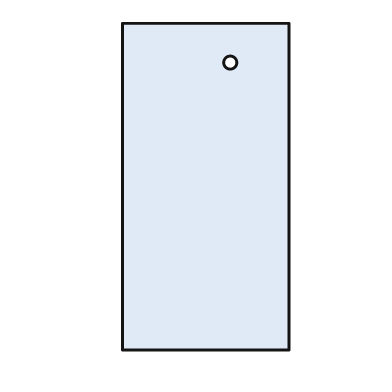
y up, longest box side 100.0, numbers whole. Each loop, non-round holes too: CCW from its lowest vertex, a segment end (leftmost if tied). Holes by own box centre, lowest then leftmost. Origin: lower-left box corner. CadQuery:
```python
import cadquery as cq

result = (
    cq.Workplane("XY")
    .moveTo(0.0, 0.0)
    .lineTo(51.0, 0.0)
    .lineTo(51.0, 100.0)
    .lineTo(0.0, 100.0)
    .close()
    .moveTo(33.0, 88.0)
    .circle(2.0)
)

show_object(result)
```